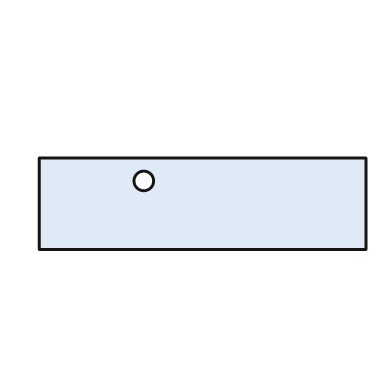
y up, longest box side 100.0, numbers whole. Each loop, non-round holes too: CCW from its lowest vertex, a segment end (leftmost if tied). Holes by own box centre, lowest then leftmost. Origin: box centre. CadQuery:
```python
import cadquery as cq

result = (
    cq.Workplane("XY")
    .moveTo(-50.0, -14.0)
    .lineTo(50.0, -14.0)
    .lineTo(50.0, 14.0)
    .lineTo(-50.0, 14.0)
    .close()
    .moveTo(-18.0, 7.0)
    .circle(3.0)
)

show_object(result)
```